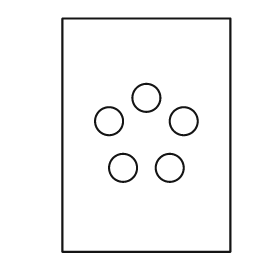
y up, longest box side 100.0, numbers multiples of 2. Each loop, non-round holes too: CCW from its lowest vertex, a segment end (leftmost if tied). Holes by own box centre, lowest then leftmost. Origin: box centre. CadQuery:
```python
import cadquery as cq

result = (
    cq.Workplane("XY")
    .moveTo(-36.0, -50.0)
    .lineTo(36.0, -50.0)
    .lineTo(36.0, 50.0)
    .lineTo(-36.0, 50.0)
    .close()
    .moveTo(-10.0, -14.0)
    .circle(6.0)
    .moveTo(10.0, -14.0)
    .circle(6.0)
    .moveTo(-16.0, 6.0)
    .circle(6.0)
    .moveTo(16.0, 6.0)
    .circle(6.0)
    .moveTo(0.0, 16.0)
    .circle(6.0)
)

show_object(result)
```